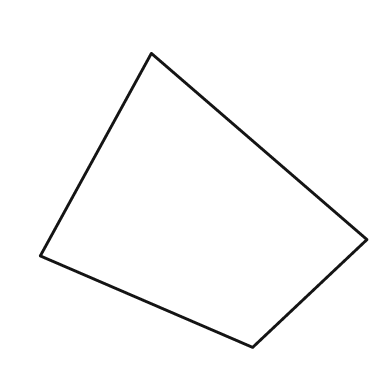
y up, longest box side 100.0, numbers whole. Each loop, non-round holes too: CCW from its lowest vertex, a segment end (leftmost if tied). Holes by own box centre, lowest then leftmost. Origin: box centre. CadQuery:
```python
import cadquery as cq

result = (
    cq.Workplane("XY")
    .moveTo(15.0, -45.0)
    .lineTo(50.0, -12.0)
    .lineTo(-16.0, 45.0)
    .lineTo(-50.0, -17.0)
    .close()
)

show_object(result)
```